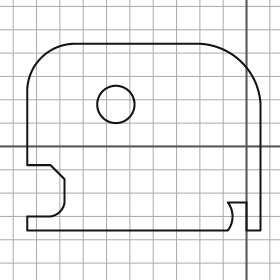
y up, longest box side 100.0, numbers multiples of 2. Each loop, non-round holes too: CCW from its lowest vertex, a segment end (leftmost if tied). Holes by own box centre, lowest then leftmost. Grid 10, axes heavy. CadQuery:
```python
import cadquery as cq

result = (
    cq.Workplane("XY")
    .moveTo(-94.0, -36.0)
    .lineTo(-8.0, -36.0)
    .threePointArc((-6.0, -30.0), (-8.0, -24.0))
    .lineTo(0.0, -24.0)
    .lineTo(0.0, -36.0)
    .lineTo(6.0, -36.0)
    .lineTo(6.0, 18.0)
    .threePointArc((-2.0, 36.0), (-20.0, 44.0))
    .lineTo(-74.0, 44.0)
    .threePointArc((-88.0, 38.0), (-94.0, 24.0))
    .lineTo(-94.0, -8.0)
    .lineTo(-84.0, -8.0)
    .lineTo(-78.0, -14.0)
    .lineTo(-78.0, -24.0)
    .threePointArc((-80.0, -28.0), (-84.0, -30.0))
    .lineTo(-94.0, -30.0)
    .close()
    .moveTo(-56.0, 18.0)
    .circle(8.0)
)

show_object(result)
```